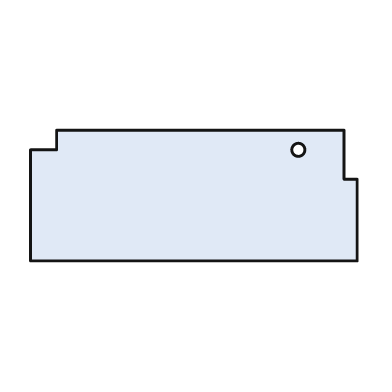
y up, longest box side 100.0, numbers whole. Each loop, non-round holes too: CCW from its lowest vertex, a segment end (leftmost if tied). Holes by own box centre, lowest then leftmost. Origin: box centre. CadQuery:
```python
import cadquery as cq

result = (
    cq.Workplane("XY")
    .moveTo(-50.0, -20.0)
    .lineTo(50.0, -20.0)
    .lineTo(50.0, 5.0)
    .lineTo(46.0, 5.0)
    .lineTo(46.0, 20.0)
    .lineTo(-42.0, 20.0)
    .lineTo(-42.0, 14.0)
    .lineTo(-50.0, 14.0)
    .close()
    .moveTo(32.0, 14.0)
    .circle(2.0)
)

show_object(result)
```